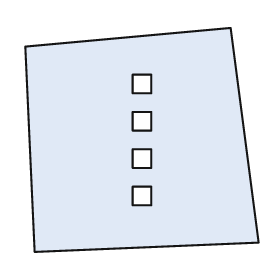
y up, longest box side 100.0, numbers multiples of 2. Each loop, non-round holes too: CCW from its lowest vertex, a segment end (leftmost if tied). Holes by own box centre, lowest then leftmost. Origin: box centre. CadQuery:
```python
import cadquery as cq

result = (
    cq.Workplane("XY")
    .moveTo(-46.0, -48.0)
    .lineTo(50.0, -44.0)
    .lineTo(38.0, 48.0)
    .lineTo(-50.0, 40.0)
    .close()
    .moveTo(-4.0, -28.0)
    .lineTo(4.0, -28.0)
    .lineTo(4.0, -20.0)
    .lineTo(-4.0, -20.0)
    .close()
    .moveTo(-4.0, -12.0)
    .lineTo(4.0, -12.0)
    .lineTo(4.0, -4.0)
    .lineTo(-4.0, -4.0)
    .close()
    .moveTo(-4.0, 4.0)
    .lineTo(4.0, 4.0)
    .lineTo(4.0, 12.0)
    .lineTo(-4.0, 12.0)
    .close()
    .moveTo(-4.0, 20.0)
    .lineTo(4.0, 20.0)
    .lineTo(4.0, 28.0)
    .lineTo(-4.0, 28.0)
    .close()
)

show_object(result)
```